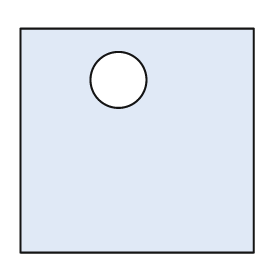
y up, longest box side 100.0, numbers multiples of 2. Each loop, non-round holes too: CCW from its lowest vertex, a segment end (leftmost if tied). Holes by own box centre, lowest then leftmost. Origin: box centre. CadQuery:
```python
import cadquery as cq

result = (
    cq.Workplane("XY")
    .moveTo(-50.0, -48.0)
    .lineTo(50.0, -48.0)
    .lineTo(50.0, 48.0)
    .lineTo(-50.0, 48.0)
    .close()
    .moveTo(-8.0, 26.0)
    .circle(12.0)
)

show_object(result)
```